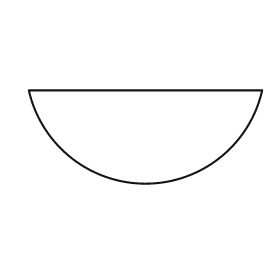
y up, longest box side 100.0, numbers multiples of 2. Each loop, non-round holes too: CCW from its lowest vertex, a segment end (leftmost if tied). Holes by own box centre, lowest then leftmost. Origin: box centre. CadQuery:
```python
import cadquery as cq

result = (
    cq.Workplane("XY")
    .moveTo(-50.0, 20.0)
    .threePointArc((0.0, -20.0), (50.0, 20.0))
    .close()
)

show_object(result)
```